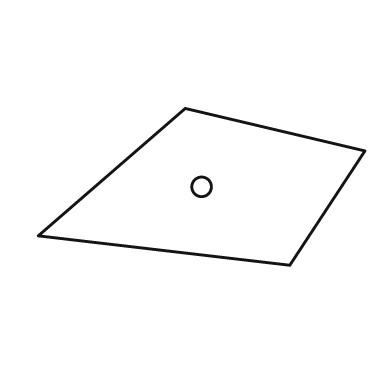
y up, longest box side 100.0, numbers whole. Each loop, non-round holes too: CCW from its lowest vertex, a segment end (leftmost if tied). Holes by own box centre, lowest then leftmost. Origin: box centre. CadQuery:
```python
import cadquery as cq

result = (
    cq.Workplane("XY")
    .moveTo(27.0, -24.0)
    .lineTo(50.0, 11.0)
    .lineTo(-5.0, 24.0)
    .lineTo(-50.0, -15.0)
    .close()
    .moveTo(0.0, 0.0)
    .circle(3.0)
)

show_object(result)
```